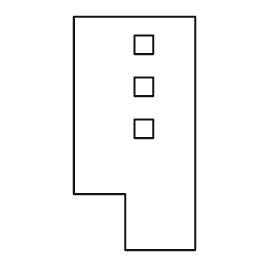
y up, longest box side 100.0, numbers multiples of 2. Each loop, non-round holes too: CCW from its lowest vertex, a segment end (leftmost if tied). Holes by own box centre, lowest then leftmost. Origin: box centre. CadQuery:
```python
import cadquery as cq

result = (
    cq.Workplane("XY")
    .moveTo(-4.0, -50.0)
    .lineTo(26.0, -50.0)
    .lineTo(26.0, 50.0)
    .lineTo(-26.0, 50.0)
    .lineTo(-26.0, -26.0)
    .lineTo(-4.0, -26.0)
    .close()
    .moveTo(0.0, -2.0)
    .lineTo(8.0, -2.0)
    .lineTo(8.0, 6.0)
    .lineTo(0.0, 6.0)
    .close()
    .moveTo(0.0, 16.0)
    .lineTo(8.0, 16.0)
    .lineTo(8.0, 24.0)
    .lineTo(0.0, 24.0)
    .close()
    .moveTo(0.0, 34.0)
    .lineTo(8.0, 34.0)
    .lineTo(8.0, 42.0)
    .lineTo(0.0, 42.0)
    .close()
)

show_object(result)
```